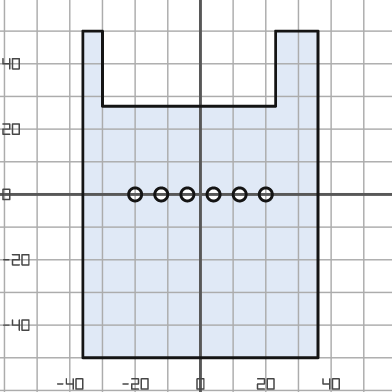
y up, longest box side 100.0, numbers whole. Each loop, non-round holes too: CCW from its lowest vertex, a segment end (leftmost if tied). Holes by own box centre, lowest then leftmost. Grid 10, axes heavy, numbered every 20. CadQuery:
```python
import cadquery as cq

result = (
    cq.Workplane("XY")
    .moveTo(-36.0, -50.0)
    .lineTo(36.0, -50.0)
    .lineTo(36.0, 50.0)
    .lineTo(23.0, 50.0)
    .lineTo(23.0, 27.0)
    .lineTo(-30.0, 27.0)
    .lineTo(-30.0, 50.0)
    .lineTo(-36.0, 50.0)
    .close()
    .moveTo(-20.0, 0.0)
    .circle(2.0)
    .moveTo(-12.0, 0.0)
    .circle(2.0)
    .moveTo(-4.0, 0.0)
    .circle(2.0)
    .moveTo(4.0, 0.0)
    .circle(2.0)
    .moveTo(12.0, 0.0)
    .circle(2.0)
    .moveTo(20.0, 0.0)
    .circle(2.0)
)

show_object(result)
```